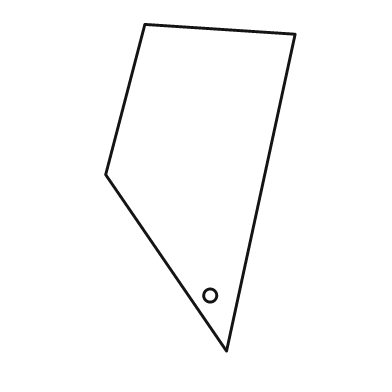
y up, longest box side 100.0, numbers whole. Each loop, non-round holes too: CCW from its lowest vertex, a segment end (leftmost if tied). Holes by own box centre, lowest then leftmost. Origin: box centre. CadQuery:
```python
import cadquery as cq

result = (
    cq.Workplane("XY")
    .moveTo(8.0, -50.0)
    .lineTo(29.0, 47.0)
    .lineTo(-17.0, 50.0)
    .lineTo(-29.0, 4.0)
    .close()
    .moveTo(3.0, -33.0)
    .circle(2.0)
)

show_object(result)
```